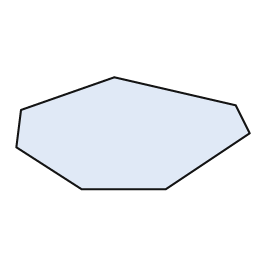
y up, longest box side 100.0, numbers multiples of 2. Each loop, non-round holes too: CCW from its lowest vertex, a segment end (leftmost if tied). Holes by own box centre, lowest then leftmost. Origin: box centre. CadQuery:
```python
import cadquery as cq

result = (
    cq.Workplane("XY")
    .moveTo(-22.0, -24.0)
    .lineTo(14.0, -24.0)
    .lineTo(50.0, 0.0)
    .lineTo(44.0, 12.0)
    .lineTo(-8.0, 24.0)
    .lineTo(-48.0, 10.0)
    .lineTo(-50.0, -6.0)
    .close()
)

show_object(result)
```